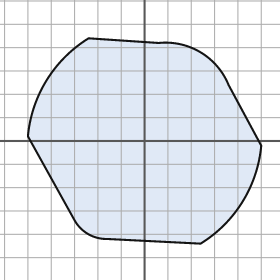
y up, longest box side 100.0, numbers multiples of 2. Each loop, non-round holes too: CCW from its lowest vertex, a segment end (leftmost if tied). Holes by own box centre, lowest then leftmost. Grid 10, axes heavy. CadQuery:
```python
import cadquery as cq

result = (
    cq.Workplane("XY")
    .moveTo(24.0, -44.0)
    .threePointArc((42.0, -26.0), (50.0, -2.0))
    .lineTo(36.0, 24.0)
    .threePointArc((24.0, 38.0), (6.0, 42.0))
    .lineTo(-24.0, 44.0)
    .threePointArc((-42.0, 26.0), (-50.0, 2.0))
    .lineTo(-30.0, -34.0)
    .threePointArc((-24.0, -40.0), (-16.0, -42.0))
    .close()
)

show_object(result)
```